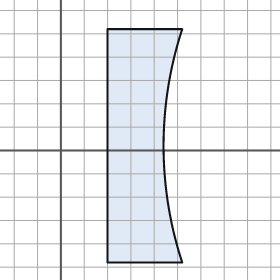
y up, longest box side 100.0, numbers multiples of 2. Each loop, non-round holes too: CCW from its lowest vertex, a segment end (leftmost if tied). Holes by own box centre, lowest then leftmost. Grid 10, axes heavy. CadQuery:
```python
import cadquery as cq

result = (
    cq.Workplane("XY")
    .moveTo(20.0, -48.0)
    .lineTo(52.0, -48.0)
    .threePointArc((44.0, 2.0), (52.0, 52.0))
    .lineTo(20.0, 52.0)
    .close()
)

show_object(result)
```